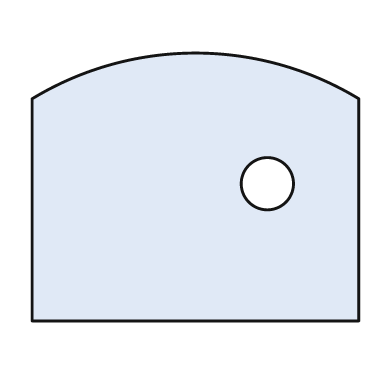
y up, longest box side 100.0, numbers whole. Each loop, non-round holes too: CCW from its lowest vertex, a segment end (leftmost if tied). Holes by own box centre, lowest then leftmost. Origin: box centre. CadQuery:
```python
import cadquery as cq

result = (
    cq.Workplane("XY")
    .moveTo(-50.0, -41.0)
    .lineTo(50.0, -41.0)
    .lineTo(50.0, 27.0)
    .threePointArc((0.0, 41.0), (-50.0, 27.0))
    .close()
    .moveTo(22.0, 1.0)
    .circle(8.0)
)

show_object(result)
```